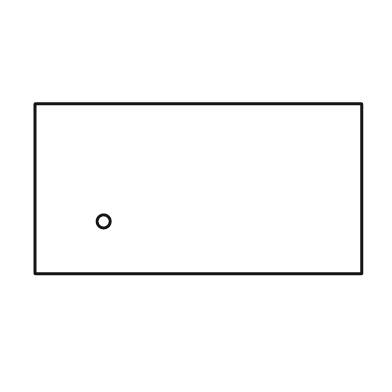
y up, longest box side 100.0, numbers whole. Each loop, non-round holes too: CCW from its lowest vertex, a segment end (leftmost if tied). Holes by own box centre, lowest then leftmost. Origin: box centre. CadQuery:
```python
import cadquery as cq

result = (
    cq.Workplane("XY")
    .moveTo(-50.0, -26.0)
    .lineTo(50.0, -26.0)
    .lineTo(50.0, 26.0)
    .lineTo(-50.0, 26.0)
    .close()
    .moveTo(-29.0, -10.0)
    .circle(2.0)
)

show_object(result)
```